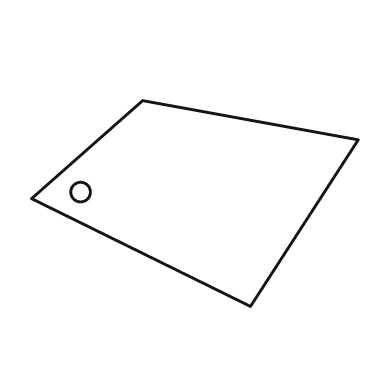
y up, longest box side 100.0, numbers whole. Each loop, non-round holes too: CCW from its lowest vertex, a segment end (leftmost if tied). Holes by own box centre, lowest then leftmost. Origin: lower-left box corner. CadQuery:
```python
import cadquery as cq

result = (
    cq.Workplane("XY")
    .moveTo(67.0, 0.0)
    .lineTo(100.0, 51.0)
    .lineTo(34.0, 63.0)
    .lineTo(0.0, 33.0)
    .close()
    .moveTo(15.0, 35.0)
    .circle(3.0)
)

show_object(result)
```